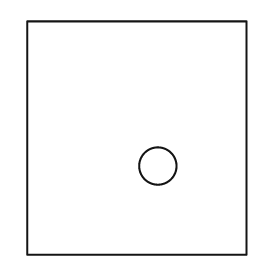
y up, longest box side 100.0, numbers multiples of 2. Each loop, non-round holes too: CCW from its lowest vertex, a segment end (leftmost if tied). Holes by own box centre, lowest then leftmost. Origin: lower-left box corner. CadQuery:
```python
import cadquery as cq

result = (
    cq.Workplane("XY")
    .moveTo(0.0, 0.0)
    .lineTo(94.0, 0.0)
    .lineTo(94.0, 100.0)
    .lineTo(0.0, 100.0)
    .close()
    .moveTo(56.0, 38.0)
    .circle(8.0)
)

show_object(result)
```